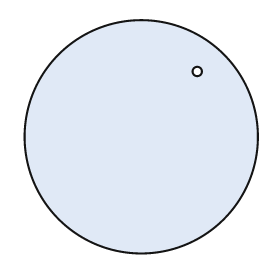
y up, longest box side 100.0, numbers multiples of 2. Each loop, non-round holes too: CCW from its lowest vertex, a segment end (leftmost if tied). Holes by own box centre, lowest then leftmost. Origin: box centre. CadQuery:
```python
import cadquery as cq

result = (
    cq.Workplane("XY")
    .moveTo(0.0, 0.0)
    .circle(50.0)
    .moveTo(24.0, 28.0)
    .circle(2.0)
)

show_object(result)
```